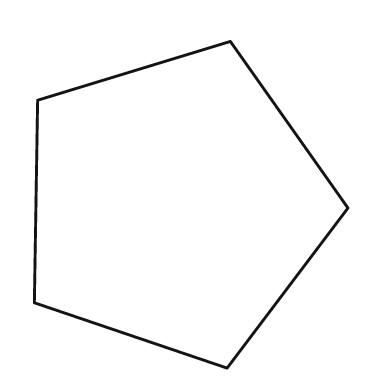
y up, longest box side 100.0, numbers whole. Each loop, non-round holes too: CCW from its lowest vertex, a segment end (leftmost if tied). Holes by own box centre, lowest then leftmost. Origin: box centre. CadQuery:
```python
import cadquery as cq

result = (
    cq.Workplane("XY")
    .moveTo(11.0, -50.0)
    .lineTo(48.0, -1.0)
    .lineTo(12.0, 50.0)
    .lineTo(-47.0, 32.0)
    .lineTo(-48.0, -30.0)
    .close()
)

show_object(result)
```